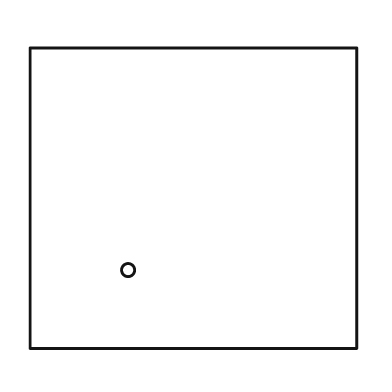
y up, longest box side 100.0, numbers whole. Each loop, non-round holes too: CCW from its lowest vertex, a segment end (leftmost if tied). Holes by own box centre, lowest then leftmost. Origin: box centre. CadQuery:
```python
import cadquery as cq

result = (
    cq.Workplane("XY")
    .moveTo(-50.0, -46.0)
    .lineTo(50.0, -46.0)
    .lineTo(50.0, 46.0)
    .lineTo(-50.0, 46.0)
    .close()
    .moveTo(-20.0, -22.0)
    .circle(2.0)
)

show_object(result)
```